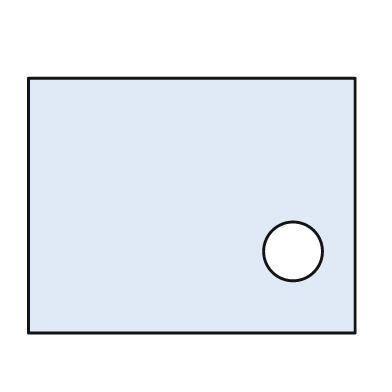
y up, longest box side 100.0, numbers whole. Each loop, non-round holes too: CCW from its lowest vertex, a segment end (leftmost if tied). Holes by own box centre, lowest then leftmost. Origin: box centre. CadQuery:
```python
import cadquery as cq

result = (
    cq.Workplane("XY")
    .moveTo(-50.0, -39.0)
    .lineTo(50.0, -39.0)
    .lineTo(50.0, 39.0)
    .lineTo(-50.0, 39.0)
    .close()
    .moveTo(31.0, -14.0)
    .circle(9.0)
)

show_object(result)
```